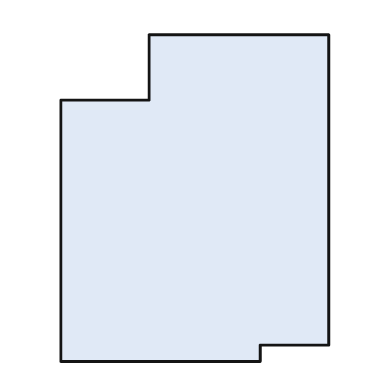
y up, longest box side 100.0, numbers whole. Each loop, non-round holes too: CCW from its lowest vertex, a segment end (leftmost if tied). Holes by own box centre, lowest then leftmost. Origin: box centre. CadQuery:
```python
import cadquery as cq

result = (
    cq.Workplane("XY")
    .moveTo(-41.0, -50.0)
    .lineTo(20.0, -50.0)
    .lineTo(20.0, -45.0)
    .lineTo(41.0, -45.0)
    .lineTo(41.0, 50.0)
    .lineTo(-14.0, 50.0)
    .lineTo(-14.0, 30.0)
    .lineTo(-41.0, 30.0)
    .close()
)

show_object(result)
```